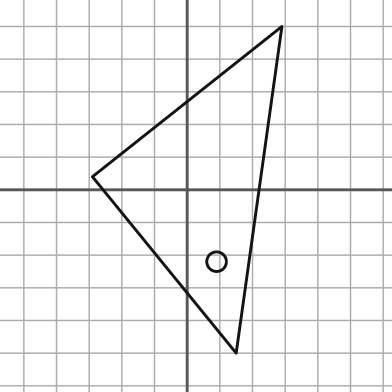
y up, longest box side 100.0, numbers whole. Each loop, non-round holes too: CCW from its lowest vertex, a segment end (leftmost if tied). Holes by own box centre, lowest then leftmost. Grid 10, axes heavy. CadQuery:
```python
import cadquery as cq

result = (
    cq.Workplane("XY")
    .moveTo(15.0, -50.0)
    .lineTo(29.0, 50.0)
    .lineTo(-29.0, 4.0)
    .close()
    .moveTo(9.0, -22.0)
    .circle(3.0)
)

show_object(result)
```